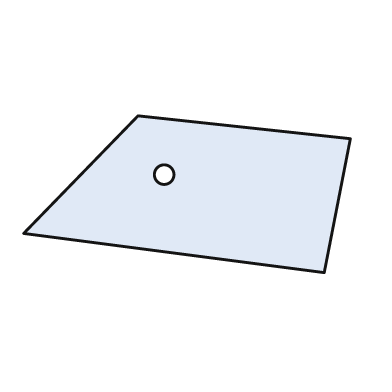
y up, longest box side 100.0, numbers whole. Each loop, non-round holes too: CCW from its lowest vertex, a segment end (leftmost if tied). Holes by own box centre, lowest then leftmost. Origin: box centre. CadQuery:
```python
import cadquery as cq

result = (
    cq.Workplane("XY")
    .moveTo(42.0, -24.0)
    .lineTo(50.0, 17.0)
    .lineTo(-15.0, 24.0)
    .lineTo(-50.0, -12.0)
    .close()
    .moveTo(-7.0, 6.0)
    .circle(3.0)
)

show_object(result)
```